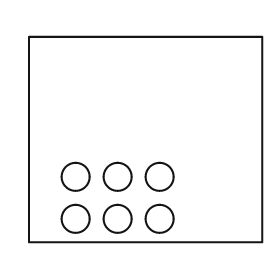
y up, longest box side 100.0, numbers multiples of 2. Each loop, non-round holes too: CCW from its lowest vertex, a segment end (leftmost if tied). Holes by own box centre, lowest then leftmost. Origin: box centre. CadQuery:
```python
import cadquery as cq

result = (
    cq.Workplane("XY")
    .moveTo(-50.0, -44.0)
    .lineTo(50.0, -44.0)
    .lineTo(50.0, 44.0)
    .lineTo(-50.0, 44.0)
    .close()
    .moveTo(-30.0, -34.0)
    .circle(6.0)
    .moveTo(-12.0, -34.0)
    .circle(6.0)
    .moveTo(6.0, -34.0)
    .circle(6.0)
    .moveTo(-30.0, -16.0)
    .circle(6.0)
    .moveTo(-12.0, -16.0)
    .circle(6.0)
    .moveTo(6.0, -16.0)
    .circle(6.0)
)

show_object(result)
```